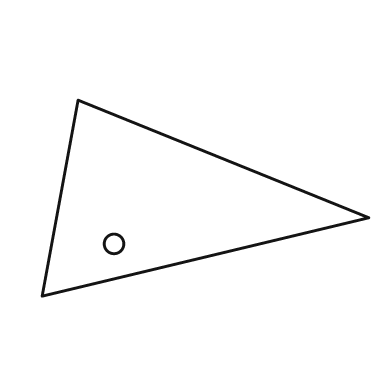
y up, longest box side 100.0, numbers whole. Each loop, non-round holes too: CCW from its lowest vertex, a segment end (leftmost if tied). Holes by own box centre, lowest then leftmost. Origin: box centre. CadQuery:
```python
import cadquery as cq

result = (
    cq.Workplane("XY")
    .moveTo(-50.0, -30.0)
    .lineTo(50.0, -6.0)
    .lineTo(-39.0, 30.0)
    .close()
    .moveTo(-28.0, -14.0)
    .circle(3.0)
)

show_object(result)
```